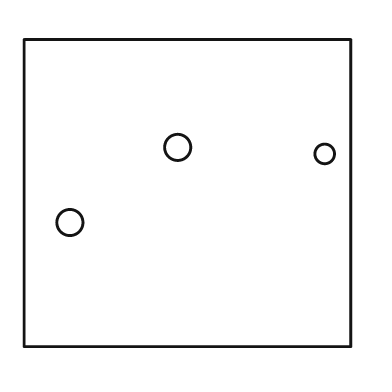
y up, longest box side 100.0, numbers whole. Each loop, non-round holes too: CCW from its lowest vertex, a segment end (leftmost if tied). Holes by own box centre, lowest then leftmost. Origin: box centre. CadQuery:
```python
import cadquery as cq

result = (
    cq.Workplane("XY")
    .moveTo(-50.0, -47.0)
    .lineTo(50.0, -47.0)
    .lineTo(50.0, 47.0)
    .lineTo(-50.0, 47.0)
    .close()
    .moveTo(-36.0, -9.0)
    .circle(4.0)
    .moveTo(42.0, 12.0)
    .circle(3.0)
    .moveTo(-3.0, 14.0)
    .circle(4.0)
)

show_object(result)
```